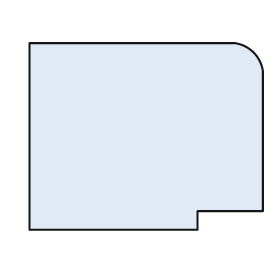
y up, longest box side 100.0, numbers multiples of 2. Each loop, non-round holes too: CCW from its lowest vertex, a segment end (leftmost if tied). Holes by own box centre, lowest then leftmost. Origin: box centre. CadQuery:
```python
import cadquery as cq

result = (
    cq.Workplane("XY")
    .moveTo(-50.0, -40.0)
    .lineTo(22.0, -40.0)
    .lineTo(22.0, -32.0)
    .lineTo(50.0, -32.0)
    .lineTo(50.0, 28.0)
    .threePointArc((46.0, 36.0), (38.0, 40.0))
    .lineTo(-50.0, 40.0)
    .close()
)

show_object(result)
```